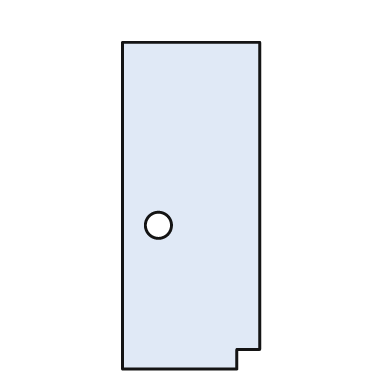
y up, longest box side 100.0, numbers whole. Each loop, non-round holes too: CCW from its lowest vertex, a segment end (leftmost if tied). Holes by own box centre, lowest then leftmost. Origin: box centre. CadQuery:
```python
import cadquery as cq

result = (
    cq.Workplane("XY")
    .moveTo(-21.0, -50.0)
    .lineTo(14.0, -50.0)
    .lineTo(14.0, -44.0)
    .lineTo(21.0, -44.0)
    .lineTo(21.0, 50.0)
    .lineTo(-21.0, 50.0)
    .close()
    .moveTo(-10.0, -6.0)
    .circle(4.0)
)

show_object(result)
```